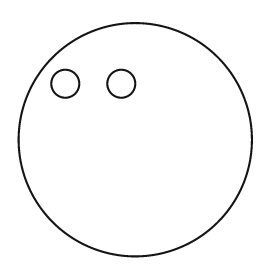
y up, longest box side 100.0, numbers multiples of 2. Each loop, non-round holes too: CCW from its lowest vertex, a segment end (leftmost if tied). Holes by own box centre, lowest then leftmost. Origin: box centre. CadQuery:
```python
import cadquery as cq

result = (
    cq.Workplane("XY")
    .moveTo(0.0, 0.0)
    .circle(50.0)
    .moveTo(-30.0, 24.0)
    .circle(6.0)
    .moveTo(-6.0, 24.0)
    .circle(6.0)
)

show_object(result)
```